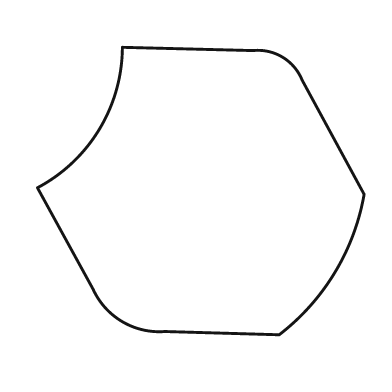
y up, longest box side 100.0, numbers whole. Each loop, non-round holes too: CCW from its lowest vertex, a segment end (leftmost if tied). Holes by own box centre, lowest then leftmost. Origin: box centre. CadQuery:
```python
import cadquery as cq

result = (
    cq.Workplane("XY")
    .moveTo(24.0, -44.0)
    .threePointArc((41.0, -25.0), (50.0, -1.0))
    .lineTo(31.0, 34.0)
    .threePointArc((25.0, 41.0), (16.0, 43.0))
    .lineTo(-24.0, 44.0)
    .threePointArc((-31.0, 19.0), (-50.0, 1.0))
    .lineTo(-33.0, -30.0)
    .threePointArc((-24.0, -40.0), (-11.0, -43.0))
    .close()
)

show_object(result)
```